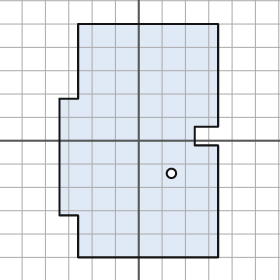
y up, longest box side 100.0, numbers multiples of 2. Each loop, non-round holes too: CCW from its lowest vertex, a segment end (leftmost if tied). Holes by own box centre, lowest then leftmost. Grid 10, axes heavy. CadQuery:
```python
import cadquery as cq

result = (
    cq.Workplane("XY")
    .moveTo(-26.0, -50.0)
    .lineTo(34.0, -50.0)
    .lineTo(34.0, -2.0)
    .lineTo(24.0, -2.0)
    .lineTo(24.0, 6.0)
    .lineTo(34.0, 6.0)
    .lineTo(34.0, 50.0)
    .lineTo(-26.0, 50.0)
    .lineTo(-26.0, 18.0)
    .lineTo(-34.0, 18.0)
    .lineTo(-34.0, -32.0)
    .lineTo(-26.0, -32.0)
    .close()
    .moveTo(14.0, -14.0)
    .circle(2.0)
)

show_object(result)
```